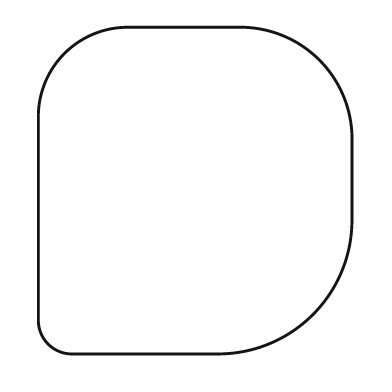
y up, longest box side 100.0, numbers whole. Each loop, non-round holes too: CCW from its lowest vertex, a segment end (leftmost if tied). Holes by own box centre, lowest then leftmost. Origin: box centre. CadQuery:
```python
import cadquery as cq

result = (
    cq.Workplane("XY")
    .moveTo(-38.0, -50.0)
    .lineTo(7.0, -50.0)
    .threePointArc((36.0, -38.0), (48.0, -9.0))
    .lineTo(48.0, 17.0)
    .threePointArc((38.0, 40.0), (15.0, 50.0))
    .lineTo(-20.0, 50.0)
    .threePointArc((-40.0, 42.0), (-48.0, 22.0))
    .lineTo(-48.0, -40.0)
    .threePointArc((-45.0, -47.0), (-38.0, -50.0))
    .close()
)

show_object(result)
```